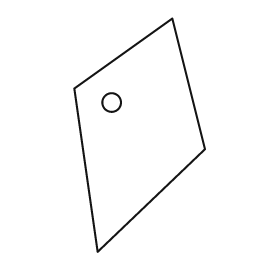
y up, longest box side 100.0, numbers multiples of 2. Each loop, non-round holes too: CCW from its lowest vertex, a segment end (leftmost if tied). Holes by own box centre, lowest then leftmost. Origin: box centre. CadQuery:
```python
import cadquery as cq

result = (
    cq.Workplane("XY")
    .moveTo(-18.0, -50.0)
    .lineTo(28.0, -6.0)
    .lineTo(14.0, 50.0)
    .lineTo(-28.0, 20.0)
    .close()
    .moveTo(-12.0, 14.0)
    .circle(4.0)
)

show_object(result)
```